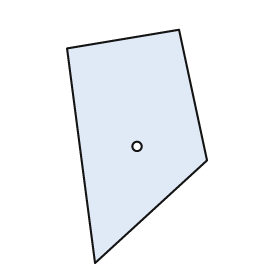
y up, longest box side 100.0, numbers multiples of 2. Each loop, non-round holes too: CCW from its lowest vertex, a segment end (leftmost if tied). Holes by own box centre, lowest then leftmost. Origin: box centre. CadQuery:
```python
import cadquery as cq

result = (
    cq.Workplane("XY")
    .moveTo(-18.0, -50.0)
    .lineTo(30.0, -6.0)
    .lineTo(18.0, 50.0)
    .lineTo(-30.0, 42.0)
    .close()
    .moveTo(0.0, 0.0)
    .circle(2.0)
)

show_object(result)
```